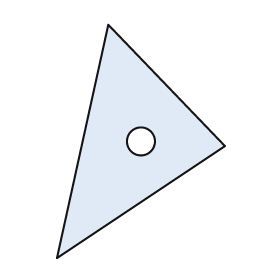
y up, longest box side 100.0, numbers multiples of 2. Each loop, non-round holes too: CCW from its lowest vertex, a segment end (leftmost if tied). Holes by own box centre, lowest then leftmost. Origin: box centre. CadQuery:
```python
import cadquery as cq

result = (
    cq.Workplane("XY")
    .moveTo(-36.0, -50.0)
    .lineTo(36.0, -2.0)
    .lineTo(-14.0, 50.0)
    .close()
    .moveTo(0.0, 0.0)
    .circle(6.0)
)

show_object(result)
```